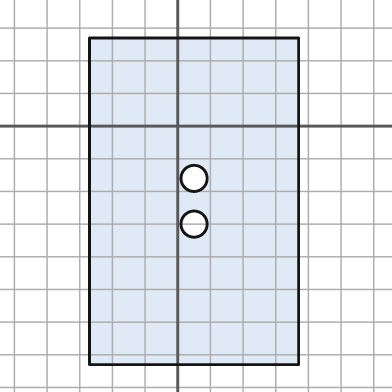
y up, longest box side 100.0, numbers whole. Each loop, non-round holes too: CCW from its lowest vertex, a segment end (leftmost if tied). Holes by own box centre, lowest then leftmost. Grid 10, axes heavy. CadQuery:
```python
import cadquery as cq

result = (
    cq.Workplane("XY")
    .moveTo(-27.0, -73.0)
    .lineTo(37.0, -73.0)
    .lineTo(37.0, 27.0)
    .lineTo(-27.0, 27.0)
    .close()
    .moveTo(5.0, -30.0)
    .circle(4.0)
    .moveTo(5.0, -16.0)
    .circle(4.0)
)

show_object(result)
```